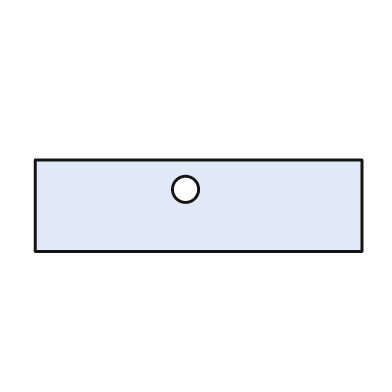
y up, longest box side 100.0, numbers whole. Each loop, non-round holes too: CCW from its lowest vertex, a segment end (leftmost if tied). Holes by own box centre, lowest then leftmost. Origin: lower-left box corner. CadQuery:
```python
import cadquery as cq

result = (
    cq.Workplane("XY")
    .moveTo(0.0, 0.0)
    .lineTo(100.0, 0.0)
    .lineTo(100.0, 28.0)
    .lineTo(0.0, 28.0)
    .close()
    .moveTo(46.0, 19.0)
    .circle(4.0)
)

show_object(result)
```